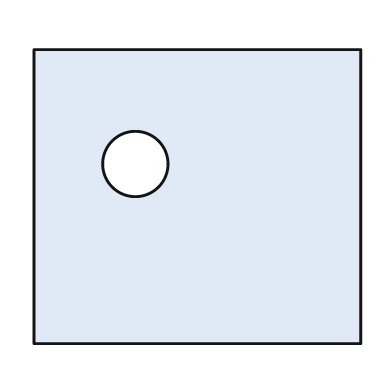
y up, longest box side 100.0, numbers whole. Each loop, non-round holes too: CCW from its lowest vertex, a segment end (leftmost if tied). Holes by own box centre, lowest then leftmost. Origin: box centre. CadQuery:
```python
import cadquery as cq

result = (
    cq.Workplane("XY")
    .moveTo(-50.0, -45.0)
    .lineTo(50.0, -45.0)
    .lineTo(50.0, 45.0)
    .lineTo(-50.0, 45.0)
    .close()
    .moveTo(-19.0, 10.0)
    .circle(10.0)
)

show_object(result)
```